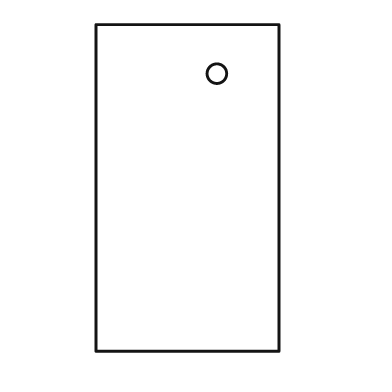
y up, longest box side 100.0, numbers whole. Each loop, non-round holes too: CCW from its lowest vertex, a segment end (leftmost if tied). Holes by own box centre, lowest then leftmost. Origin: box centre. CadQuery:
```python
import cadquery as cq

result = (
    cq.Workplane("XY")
    .moveTo(-28.0, -50.0)
    .lineTo(28.0, -50.0)
    .lineTo(28.0, 50.0)
    .lineTo(-28.0, 50.0)
    .close()
    .moveTo(9.0, 35.0)
    .circle(3.0)
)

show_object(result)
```